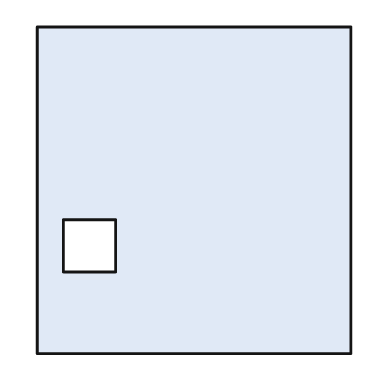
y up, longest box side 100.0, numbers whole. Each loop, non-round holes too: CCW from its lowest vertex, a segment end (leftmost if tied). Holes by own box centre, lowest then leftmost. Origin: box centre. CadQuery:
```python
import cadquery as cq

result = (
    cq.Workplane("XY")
    .moveTo(-48.0, -50.0)
    .lineTo(48.0, -50.0)
    .lineTo(48.0, 50.0)
    .lineTo(-48.0, 50.0)
    .close()
    .moveTo(-40.0, -25.0)
    .lineTo(-24.0, -25.0)
    .lineTo(-24.0, -9.0)
    .lineTo(-40.0, -9.0)
    .close()
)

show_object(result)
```